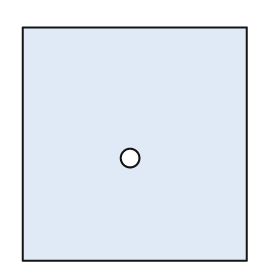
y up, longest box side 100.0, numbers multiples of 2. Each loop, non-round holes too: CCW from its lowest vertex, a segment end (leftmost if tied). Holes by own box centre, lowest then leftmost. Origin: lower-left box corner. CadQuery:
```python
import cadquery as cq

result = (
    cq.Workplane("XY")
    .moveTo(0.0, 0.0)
    .lineTo(96.0, 0.0)
    .lineTo(96.0, 100.0)
    .lineTo(0.0, 100.0)
    .close()
    .moveTo(46.0, 44.0)
    .circle(4.0)
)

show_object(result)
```